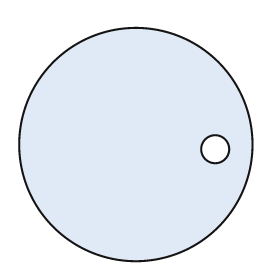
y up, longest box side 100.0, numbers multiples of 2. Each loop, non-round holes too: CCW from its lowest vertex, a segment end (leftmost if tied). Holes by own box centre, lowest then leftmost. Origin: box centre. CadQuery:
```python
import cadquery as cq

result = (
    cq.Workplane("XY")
    .moveTo(0.0, 0.0)
    .circle(50.0)
    .moveTo(34.0, -2.0)
    .circle(6.0)
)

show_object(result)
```